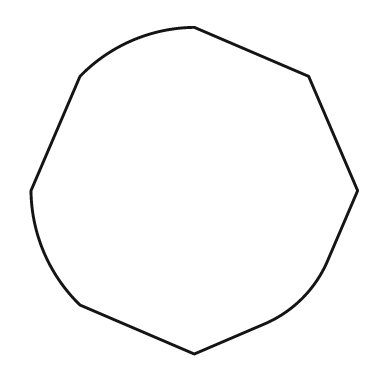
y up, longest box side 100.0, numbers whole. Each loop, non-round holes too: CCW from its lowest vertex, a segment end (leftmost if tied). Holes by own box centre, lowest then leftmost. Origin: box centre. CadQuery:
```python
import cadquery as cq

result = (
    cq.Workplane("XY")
    .moveTo(0.0, -50.0)
    .lineTo(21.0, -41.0)
    .threePointArc((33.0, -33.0), (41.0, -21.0))
    .lineTo(50.0, 0.0)
    .lineTo(35.0, 35.0)
    .lineTo(0.0, 50.0)
    .threePointArc((-19.0, 46.0), (-35.0, 35.0))
    .lineTo(-50.0, 0.0)
    .threePointArc((-46.0, -19.0), (-35.0, -35.0))
    .close()
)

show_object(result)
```